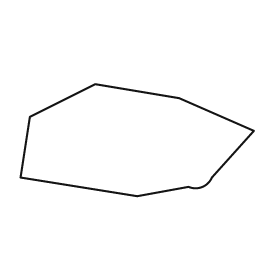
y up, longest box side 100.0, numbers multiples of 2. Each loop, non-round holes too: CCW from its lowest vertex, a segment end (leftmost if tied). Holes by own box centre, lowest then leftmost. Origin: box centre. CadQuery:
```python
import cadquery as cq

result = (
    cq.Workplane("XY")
    .moveTo(0.0, -24.0)
    .lineTo(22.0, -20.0)
    .threePointArc((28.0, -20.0), (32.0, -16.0))
    .lineTo(50.0, 4.0)
    .lineTo(18.0, 18.0)
    .lineTo(-18.0, 24.0)
    .lineTo(-46.0, 10.0)
    .lineTo(-50.0, -16.0)
    .close()
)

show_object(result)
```